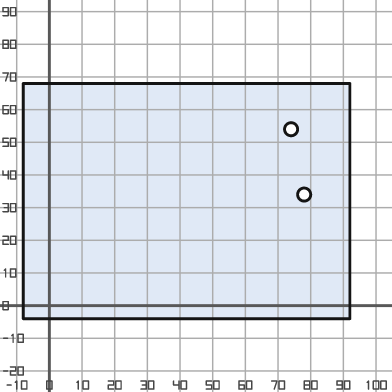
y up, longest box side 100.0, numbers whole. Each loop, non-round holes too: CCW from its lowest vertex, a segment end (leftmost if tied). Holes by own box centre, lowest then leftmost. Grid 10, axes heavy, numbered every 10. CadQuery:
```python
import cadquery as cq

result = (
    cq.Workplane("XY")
    .moveTo(-8.0, -4.0)
    .lineTo(92.0, -4.0)
    .lineTo(92.0, 68.0)
    .lineTo(-8.0, 68.0)
    .close()
    .moveTo(78.0, 34.0)
    .circle(2.0)
    .moveTo(74.0, 54.0)
    .circle(2.0)
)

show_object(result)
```